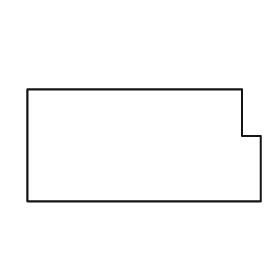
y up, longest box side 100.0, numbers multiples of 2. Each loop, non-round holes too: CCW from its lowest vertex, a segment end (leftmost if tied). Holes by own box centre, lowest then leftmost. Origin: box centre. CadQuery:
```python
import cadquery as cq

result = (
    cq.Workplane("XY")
    .moveTo(-50.0, -24.0)
    .lineTo(50.0, -24.0)
    .lineTo(50.0, 4.0)
    .lineTo(42.0, 4.0)
    .lineTo(42.0, 24.0)
    .lineTo(-50.0, 24.0)
    .close()
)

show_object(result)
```